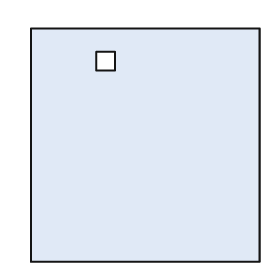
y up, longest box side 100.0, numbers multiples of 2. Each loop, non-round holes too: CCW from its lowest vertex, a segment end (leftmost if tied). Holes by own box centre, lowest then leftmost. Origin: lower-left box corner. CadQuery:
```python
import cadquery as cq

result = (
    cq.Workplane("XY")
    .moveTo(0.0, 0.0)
    .lineTo(98.0, 0.0)
    .lineTo(98.0, 100.0)
    .lineTo(0.0, 100.0)
    .close()
    .moveTo(28.0, 82.0)
    .lineTo(36.0, 82.0)
    .lineTo(36.0, 90.0)
    .lineTo(28.0, 90.0)
    .close()
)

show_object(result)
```